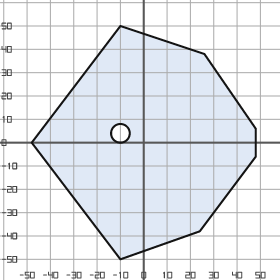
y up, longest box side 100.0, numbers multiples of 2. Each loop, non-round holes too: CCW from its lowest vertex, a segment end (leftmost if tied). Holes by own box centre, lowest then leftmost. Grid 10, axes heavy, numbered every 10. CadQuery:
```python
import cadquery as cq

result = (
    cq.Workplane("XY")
    .moveTo(-10.0, -50.0)
    .lineTo(24.0, -38.0)
    .lineTo(48.0, -6.0)
    .lineTo(48.0, 6.0)
    .lineTo(26.0, 38.0)
    .lineTo(-10.0, 50.0)
    .lineTo(-48.0, 0.0)
    .close()
    .moveTo(-10.0, 4.0)
    .circle(4.0)
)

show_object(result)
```